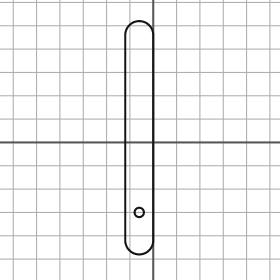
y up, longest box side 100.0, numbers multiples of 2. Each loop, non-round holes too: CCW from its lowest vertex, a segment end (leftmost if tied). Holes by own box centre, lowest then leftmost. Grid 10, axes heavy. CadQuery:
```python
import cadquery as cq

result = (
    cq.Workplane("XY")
    .moveTo(-12.0, -42.0)
    .threePointArc((-6.0, -48.0), (0.0, -42.0))
    .lineTo(0.0, 46.0)
    .threePointArc((-6.0, 52.0), (-12.0, 46.0))
    .close()
    .moveTo(-6.0, -30.0)
    .circle(2.0)
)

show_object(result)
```